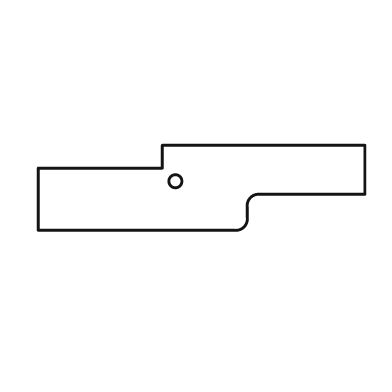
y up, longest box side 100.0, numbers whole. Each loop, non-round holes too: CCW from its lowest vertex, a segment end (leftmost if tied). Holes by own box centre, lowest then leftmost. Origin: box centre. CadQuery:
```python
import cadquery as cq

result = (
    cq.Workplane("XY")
    .moveTo(-50.0, -13.0)
    .lineTo(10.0, -13.0)
    .threePointArc((13.0, -12.0), (14.0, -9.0))
    .lineTo(14.0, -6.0)
    .threePointArc((15.0, -3.0), (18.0, -2.0))
    .lineTo(50.0, -2.0)
    .lineTo(50.0, 13.0)
    .lineTo(-12.0, 13.0)
    .lineTo(-12.0, 6.0)
    .lineTo(-50.0, 6.0)
    .close()
    .moveTo(-8.0, 2.0)
    .circle(2.0)
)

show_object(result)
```